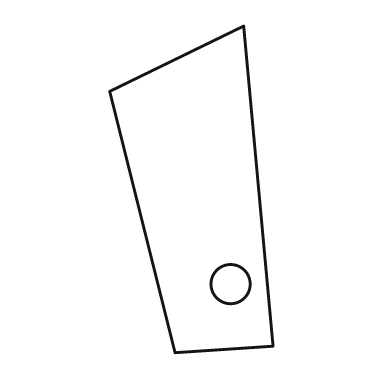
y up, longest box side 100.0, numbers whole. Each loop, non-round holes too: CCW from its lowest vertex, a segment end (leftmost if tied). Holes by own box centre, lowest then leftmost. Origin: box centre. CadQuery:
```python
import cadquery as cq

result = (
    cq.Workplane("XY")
    .moveTo(-5.0, -50.0)
    .lineTo(25.0, -48.0)
    .lineTo(16.0, 50.0)
    .lineTo(-25.0, 30.0)
    .close()
    .moveTo(12.0, -29.0)
    .circle(6.0)
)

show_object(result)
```